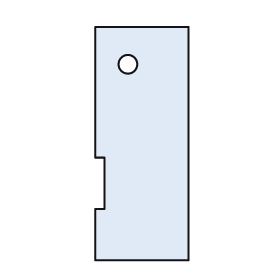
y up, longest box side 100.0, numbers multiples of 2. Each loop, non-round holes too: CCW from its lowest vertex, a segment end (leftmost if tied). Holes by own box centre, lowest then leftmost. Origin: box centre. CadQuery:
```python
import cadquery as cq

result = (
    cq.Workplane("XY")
    .moveTo(-20.0, -50.0)
    .lineTo(20.0, -50.0)
    .lineTo(20.0, 50.0)
    .lineTo(-20.0, 50.0)
    .lineTo(-20.0, -6.0)
    .lineTo(-16.0, -6.0)
    .lineTo(-16.0, -28.0)
    .lineTo(-20.0, -28.0)
    .close()
    .moveTo(-6.0, 34.0)
    .circle(4.0)
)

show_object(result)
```